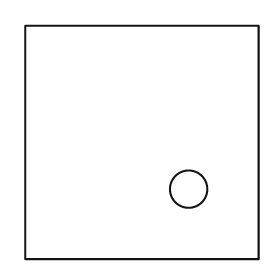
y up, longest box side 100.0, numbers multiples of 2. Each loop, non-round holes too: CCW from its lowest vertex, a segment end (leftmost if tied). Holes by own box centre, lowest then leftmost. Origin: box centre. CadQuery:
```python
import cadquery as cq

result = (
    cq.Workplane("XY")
    .moveTo(-50.0, -50.0)
    .lineTo(50.0, -50.0)
    .lineTo(50.0, 50.0)
    .lineTo(-50.0, 50.0)
    .close()
    .moveTo(20.0, -20.0)
    .circle(8.0)
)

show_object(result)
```